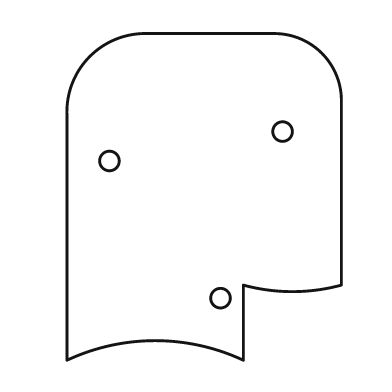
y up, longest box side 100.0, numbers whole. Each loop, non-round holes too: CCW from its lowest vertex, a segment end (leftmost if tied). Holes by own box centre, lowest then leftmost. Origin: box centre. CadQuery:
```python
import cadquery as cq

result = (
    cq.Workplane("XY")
    .moveTo(-42.0, -50.0)
    .threePointArc((-15.0, -44.0), (12.0, -50.0))
    .lineTo(12.0, -27.0)
    .threePointArc((27.0, -29.0), (42.0, -27.0))
    .lineTo(42.0, 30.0)
    .threePointArc((36.0, 44.0), (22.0, 50.0))
    .lineTo(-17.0, 50.0)
    .threePointArc((-35.0, 43.0), (-42.0, 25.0))
    .close()
    .moveTo(5.0, -31.0)
    .circle(3.0)
    .moveTo(-29.0, 11.0)
    .circle(3.0)
    .moveTo(24.0, 20.0)
    .circle(3.0)
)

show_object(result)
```